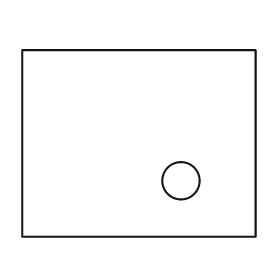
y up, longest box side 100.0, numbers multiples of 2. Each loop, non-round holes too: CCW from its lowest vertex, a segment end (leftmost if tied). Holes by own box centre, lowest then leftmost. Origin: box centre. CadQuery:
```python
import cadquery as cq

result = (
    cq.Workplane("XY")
    .moveTo(-50.0, -40.0)
    .lineTo(50.0, -40.0)
    .lineTo(50.0, 40.0)
    .lineTo(-50.0, 40.0)
    .close()
    .moveTo(18.0, -16.0)
    .circle(8.0)
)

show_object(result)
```